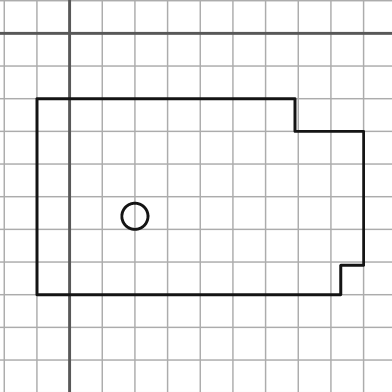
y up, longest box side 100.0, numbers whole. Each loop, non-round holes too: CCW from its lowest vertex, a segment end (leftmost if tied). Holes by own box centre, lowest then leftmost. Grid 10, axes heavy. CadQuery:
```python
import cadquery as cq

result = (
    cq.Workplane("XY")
    .moveTo(-10.0, -80.0)
    .lineTo(83.0, -80.0)
    .lineTo(83.0, -71.0)
    .lineTo(90.0, -71.0)
    .lineTo(90.0, -30.0)
    .lineTo(69.0, -30.0)
    .lineTo(69.0, -20.0)
    .lineTo(-10.0, -20.0)
    .close()
    .moveTo(20.0, -56.0)
    .circle(4.0)
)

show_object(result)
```